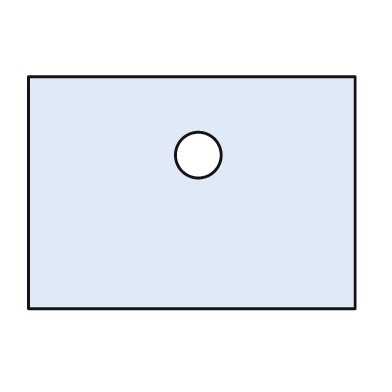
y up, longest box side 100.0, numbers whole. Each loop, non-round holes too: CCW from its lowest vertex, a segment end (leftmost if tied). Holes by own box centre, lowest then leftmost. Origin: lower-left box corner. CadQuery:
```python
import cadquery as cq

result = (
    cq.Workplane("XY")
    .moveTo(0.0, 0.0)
    .lineTo(100.0, 0.0)
    .lineTo(100.0, 71.0)
    .lineTo(0.0, 71.0)
    .close()
    .moveTo(52.0, 47.0)
    .circle(7.0)
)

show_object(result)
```